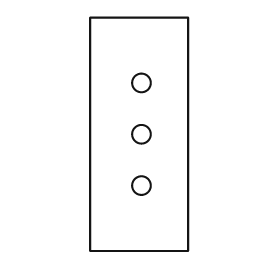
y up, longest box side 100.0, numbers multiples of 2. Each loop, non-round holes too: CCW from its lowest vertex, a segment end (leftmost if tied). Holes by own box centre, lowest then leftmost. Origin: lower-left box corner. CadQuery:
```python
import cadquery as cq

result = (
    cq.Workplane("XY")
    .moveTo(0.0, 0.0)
    .lineTo(42.0, 0.0)
    .lineTo(42.0, 100.0)
    .lineTo(0.0, 100.0)
    .close()
    .moveTo(22.0, 28.0)
    .circle(4.0)
    .moveTo(22.0, 50.0)
    .circle(4.0)
    .moveTo(22.0, 72.0)
    .circle(4.0)
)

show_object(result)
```